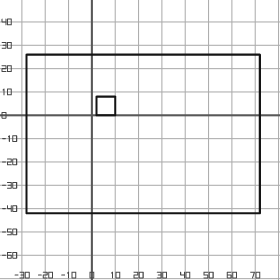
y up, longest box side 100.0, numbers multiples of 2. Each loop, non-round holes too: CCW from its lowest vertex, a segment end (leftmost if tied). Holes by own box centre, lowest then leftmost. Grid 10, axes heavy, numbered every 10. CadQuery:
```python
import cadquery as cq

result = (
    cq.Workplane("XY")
    .moveTo(-28.0, -42.0)
    .lineTo(72.0, -42.0)
    .lineTo(72.0, 26.0)
    .lineTo(-28.0, 26.0)
    .close()
    .moveTo(2.0, 0.0)
    .lineTo(10.0, 0.0)
    .lineTo(10.0, 8.0)
    .lineTo(2.0, 8.0)
    .close()
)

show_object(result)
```